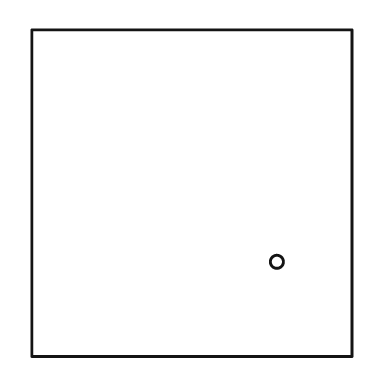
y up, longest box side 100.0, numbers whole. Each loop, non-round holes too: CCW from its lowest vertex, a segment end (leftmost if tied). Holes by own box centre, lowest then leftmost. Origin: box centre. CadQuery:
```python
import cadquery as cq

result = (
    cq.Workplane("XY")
    .moveTo(-49.0, -50.0)
    .lineTo(49.0, -50.0)
    .lineTo(49.0, 50.0)
    .lineTo(-49.0, 50.0)
    .close()
    .moveTo(26.0, -21.0)
    .circle(2.0)
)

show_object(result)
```